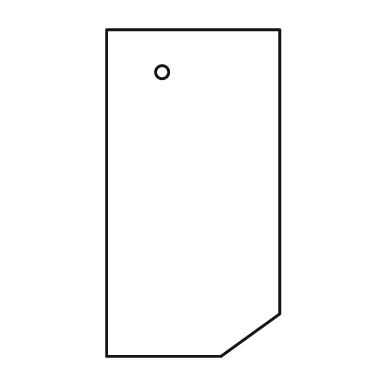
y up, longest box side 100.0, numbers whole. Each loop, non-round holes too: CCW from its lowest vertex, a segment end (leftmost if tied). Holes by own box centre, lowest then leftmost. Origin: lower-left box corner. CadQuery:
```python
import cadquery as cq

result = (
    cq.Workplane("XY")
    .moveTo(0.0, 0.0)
    .lineTo(35.0, 0.0)
    .lineTo(53.0, 13.0)
    .lineTo(53.0, 100.0)
    .lineTo(0.0, 100.0)
    .close()
    .moveTo(17.0, 87.0)
    .circle(2.0)
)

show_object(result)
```